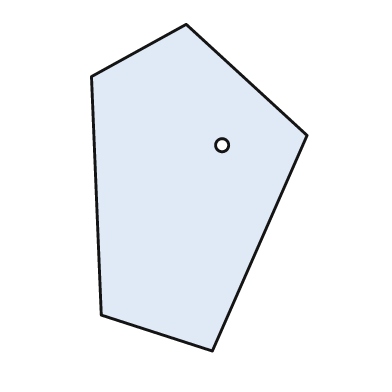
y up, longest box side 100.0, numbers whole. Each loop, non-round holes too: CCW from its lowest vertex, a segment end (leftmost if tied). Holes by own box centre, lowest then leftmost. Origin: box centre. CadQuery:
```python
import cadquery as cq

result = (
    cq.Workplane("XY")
    .moveTo(4.0, -50.0)
    .lineTo(33.0, 16.0)
    .lineTo(-4.0, 50.0)
    .lineTo(-33.0, 34.0)
    .lineTo(-30.0, -39.0)
    .close()
    .moveTo(7.0, 13.0)
    .circle(2.0)
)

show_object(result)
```